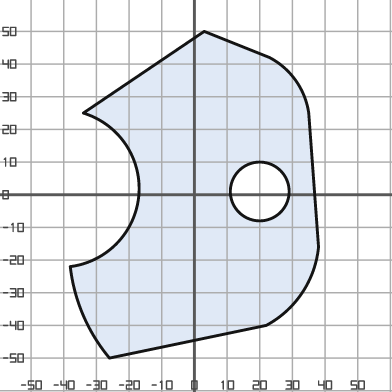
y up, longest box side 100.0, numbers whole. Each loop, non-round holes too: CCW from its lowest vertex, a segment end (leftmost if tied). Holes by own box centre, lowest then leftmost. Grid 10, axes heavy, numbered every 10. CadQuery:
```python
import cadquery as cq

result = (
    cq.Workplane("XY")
    .moveTo(-26.0, -50.0)
    .lineTo(22.0, -40.0)
    .threePointArc((33.0, -30.0), (38.0, -16.0))
    .lineTo(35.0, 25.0)
    .threePointArc((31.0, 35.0), (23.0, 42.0))
    .lineTo(3.0, 50.0)
    .lineTo(-34.0, 25.0)
    .threePointArc((-17.0, 0.0), (-38.0, -22.0))
    .threePointArc((-34.0, -37.0), (-26.0, -50.0))
    .close()
    .moveTo(20.0, 1.0)
    .circle(9.0)
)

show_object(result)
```